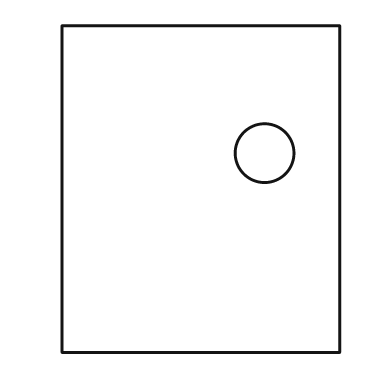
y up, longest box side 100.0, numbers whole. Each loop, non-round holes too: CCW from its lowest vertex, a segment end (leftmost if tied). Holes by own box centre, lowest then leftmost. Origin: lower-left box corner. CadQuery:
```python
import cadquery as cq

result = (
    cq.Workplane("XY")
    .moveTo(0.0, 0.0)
    .lineTo(85.0, 0.0)
    .lineTo(85.0, 100.0)
    .lineTo(0.0, 100.0)
    .close()
    .moveTo(62.0, 61.0)
    .circle(9.0)
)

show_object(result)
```